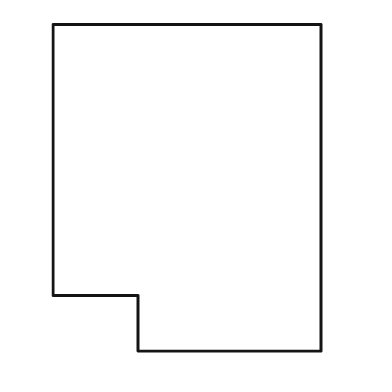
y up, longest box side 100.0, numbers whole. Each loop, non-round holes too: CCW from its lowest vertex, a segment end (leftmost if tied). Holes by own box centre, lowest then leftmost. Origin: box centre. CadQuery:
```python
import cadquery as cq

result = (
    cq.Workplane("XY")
    .moveTo(-15.0, -50.0)
    .lineTo(41.0, -50.0)
    .lineTo(41.0, 50.0)
    .lineTo(-41.0, 50.0)
    .lineTo(-41.0, -33.0)
    .lineTo(-15.0, -33.0)
    .close()
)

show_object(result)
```